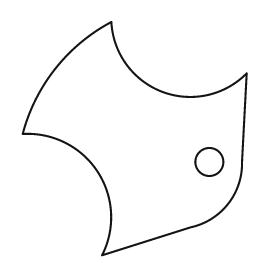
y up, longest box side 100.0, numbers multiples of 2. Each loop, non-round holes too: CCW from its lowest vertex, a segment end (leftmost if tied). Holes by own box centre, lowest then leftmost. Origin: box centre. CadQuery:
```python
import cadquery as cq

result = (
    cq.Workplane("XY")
    .moveTo(-14.0, -50.0)
    .lineTo(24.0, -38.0)
    .threePointArc((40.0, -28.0), (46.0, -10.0))
    .lineTo(48.0, 28.0)
    .threePointArc((12.0, 20.0), (-10.0, 50.0))
    .threePointArc((-34.0, 30.0), (-48.0, 2.0))
    .threePointArc((-16.0, -14.0), (-14.0, -50.0))
    .close()
    .moveTo(32.0, -10.0)
    .circle(6.0)
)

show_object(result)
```